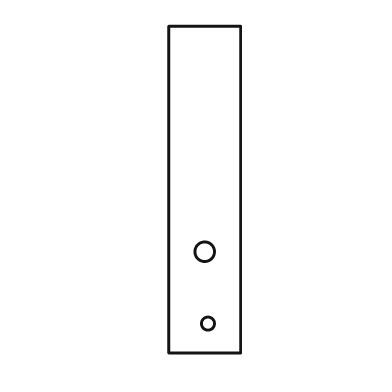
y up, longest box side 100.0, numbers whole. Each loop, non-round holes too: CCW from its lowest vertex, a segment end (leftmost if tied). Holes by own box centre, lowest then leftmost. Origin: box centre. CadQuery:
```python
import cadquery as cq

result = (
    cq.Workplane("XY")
    .moveTo(-11.0, -50.0)
    .lineTo(11.0, -50.0)
    .lineTo(11.0, 50.0)
    .lineTo(-11.0, 50.0)
    .close()
    .moveTo(1.0, -41.0)
    .circle(2.0)
    .moveTo(0.0, -19.0)
    .circle(3.0)
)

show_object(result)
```